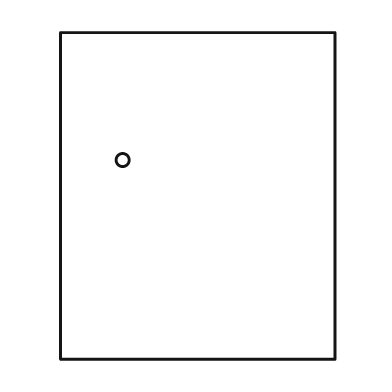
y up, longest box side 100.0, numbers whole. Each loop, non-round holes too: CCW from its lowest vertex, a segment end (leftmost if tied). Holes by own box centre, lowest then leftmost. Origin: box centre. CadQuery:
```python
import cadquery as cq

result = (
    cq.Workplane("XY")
    .moveTo(-42.0, -50.0)
    .lineTo(42.0, -50.0)
    .lineTo(42.0, 50.0)
    .lineTo(-42.0, 50.0)
    .close()
    .moveTo(-23.0, 11.0)
    .circle(2.0)
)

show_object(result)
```